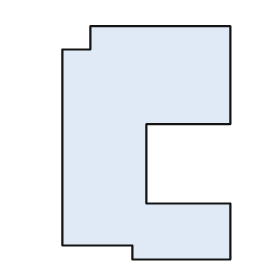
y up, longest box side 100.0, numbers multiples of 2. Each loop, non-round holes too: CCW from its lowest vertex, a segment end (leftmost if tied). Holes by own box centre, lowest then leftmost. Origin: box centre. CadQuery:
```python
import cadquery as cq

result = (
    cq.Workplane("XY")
    .moveTo(-6.0, -50.0)
    .lineTo(36.0, -50.0)
    .lineTo(36.0, -26.0)
    .lineTo(0.0, -26.0)
    .lineTo(0.0, 8.0)
    .lineTo(36.0, 8.0)
    .lineTo(36.0, 50.0)
    .lineTo(-24.0, 50.0)
    .lineTo(-24.0, 40.0)
    .lineTo(-36.0, 40.0)
    .lineTo(-36.0, -44.0)
    .lineTo(-6.0, -44.0)
    .close()
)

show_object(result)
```